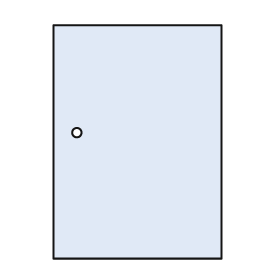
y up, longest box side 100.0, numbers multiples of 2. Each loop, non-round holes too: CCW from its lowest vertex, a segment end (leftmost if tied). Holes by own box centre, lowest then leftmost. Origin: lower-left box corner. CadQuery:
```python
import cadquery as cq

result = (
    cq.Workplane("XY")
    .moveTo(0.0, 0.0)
    .lineTo(72.0, 0.0)
    .lineTo(72.0, 100.0)
    .lineTo(0.0, 100.0)
    .close()
    .moveTo(10.0, 54.0)
    .circle(2.0)
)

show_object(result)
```